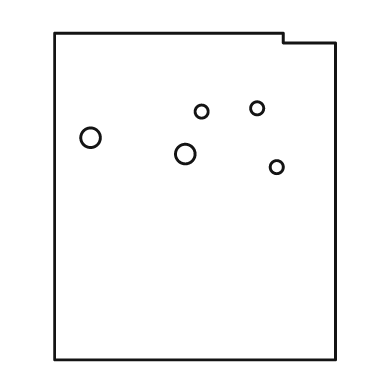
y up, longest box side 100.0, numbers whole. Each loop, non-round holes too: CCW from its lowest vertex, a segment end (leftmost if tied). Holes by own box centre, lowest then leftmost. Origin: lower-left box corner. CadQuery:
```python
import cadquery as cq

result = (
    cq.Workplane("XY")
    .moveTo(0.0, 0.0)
    .lineTo(86.0, 0.0)
    .lineTo(86.0, 97.0)
    .lineTo(70.0, 97.0)
    .lineTo(70.0, 100.0)
    .lineTo(0.0, 100.0)
    .close()
    .moveTo(68.0, 59.0)
    .circle(2.0)
    .moveTo(40.0, 63.0)
    .circle(3.0)
    .moveTo(11.0, 68.0)
    .circle(3.0)
    .moveTo(45.0, 76.0)
    .circle(2.0)
    .moveTo(62.0, 77.0)
    .circle(2.0)
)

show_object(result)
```